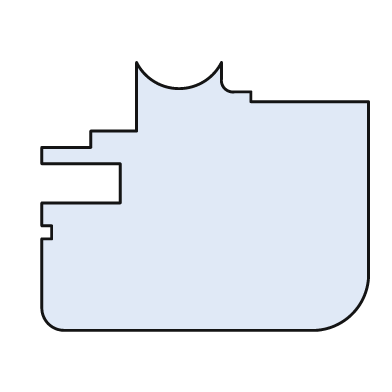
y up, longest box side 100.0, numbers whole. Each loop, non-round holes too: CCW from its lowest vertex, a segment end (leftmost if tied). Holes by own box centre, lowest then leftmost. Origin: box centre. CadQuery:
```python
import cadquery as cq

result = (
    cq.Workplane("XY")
    .moveTo(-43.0, -41.0)
    .lineTo(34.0, -41.0)
    .threePointArc((45.0, -36.0), (50.0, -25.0))
    .lineTo(50.0, 29.0)
    .lineTo(14.0, 29.0)
    .lineTo(14.0, 32.0)
    .lineTo(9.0, 32.0)
    .threePointArc((6.0, 33.0), (5.0, 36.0))
    .lineTo(5.0, 41.0)
    .threePointArc((-8.0, 33.0), (-21.0, 41.0))
    .lineTo(-21.0, 20.0)
    .lineTo(-35.0, 20.0)
    .lineTo(-35.0, 15.0)
    .lineTo(-50.0, 15.0)
    .lineTo(-50.0, 10.0)
    .lineTo(-26.0, 10.0)
    .lineTo(-26.0, -2.0)
    .lineTo(-50.0, -2.0)
    .lineTo(-50.0, -9.0)
    .lineTo(-47.0, -9.0)
    .lineTo(-47.0, -13.0)
    .lineTo(-50.0, -13.0)
    .lineTo(-50.0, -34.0)
    .threePointArc((-48.0, -39.0), (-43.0, -41.0))
    .close()
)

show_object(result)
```